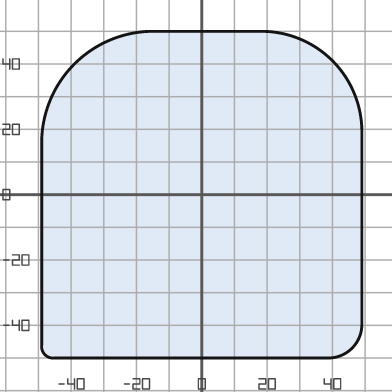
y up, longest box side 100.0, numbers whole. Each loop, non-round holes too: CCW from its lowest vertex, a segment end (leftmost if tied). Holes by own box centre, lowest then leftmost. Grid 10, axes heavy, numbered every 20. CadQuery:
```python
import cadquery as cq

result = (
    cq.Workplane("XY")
    .moveTo(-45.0, -50.0)
    .lineTo(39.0, -50.0)
    .threePointArc((46.0, -47.0), (49.0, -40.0))
    .lineTo(49.0, 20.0)
    .threePointArc((40.0, 41.0), (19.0, 50.0))
    .lineTo(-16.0, 50.0)
    .threePointArc((-39.0, 40.0), (-49.0, 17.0))
    .lineTo(-49.0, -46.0)
    .threePointArc((-48.0, -49.0), (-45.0, -50.0))
    .close()
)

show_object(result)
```